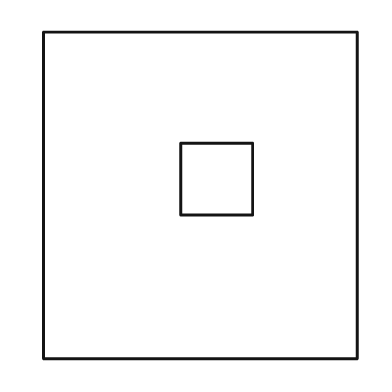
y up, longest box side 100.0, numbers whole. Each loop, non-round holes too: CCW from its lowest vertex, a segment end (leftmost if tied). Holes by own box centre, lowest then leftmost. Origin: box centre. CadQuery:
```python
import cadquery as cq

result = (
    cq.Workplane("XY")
    .moveTo(-48.0, -50.0)
    .lineTo(48.0, -50.0)
    .lineTo(48.0, 50.0)
    .lineTo(-48.0, 50.0)
    .close()
    .moveTo(-6.0, -6.0)
    .lineTo(16.0, -6.0)
    .lineTo(16.0, 16.0)
    .lineTo(-6.0, 16.0)
    .close()
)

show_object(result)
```